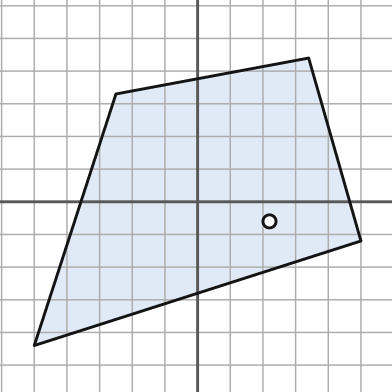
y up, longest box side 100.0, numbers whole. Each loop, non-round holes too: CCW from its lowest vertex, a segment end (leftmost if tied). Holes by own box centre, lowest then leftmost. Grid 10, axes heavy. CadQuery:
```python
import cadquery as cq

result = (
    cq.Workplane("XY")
    .moveTo(-50.0, -44.0)
    .lineTo(50.0, -12.0)
    .lineTo(34.0, 44.0)
    .lineTo(-25.0, 33.0)
    .close()
    .moveTo(22.0, -6.0)
    .circle(2.0)
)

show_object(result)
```